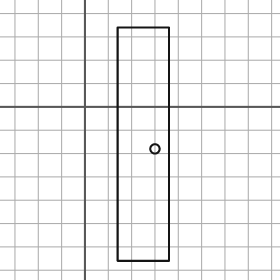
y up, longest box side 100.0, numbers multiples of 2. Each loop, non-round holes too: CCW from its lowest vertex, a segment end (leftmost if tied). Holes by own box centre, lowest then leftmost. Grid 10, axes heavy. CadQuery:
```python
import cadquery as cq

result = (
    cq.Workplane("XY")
    .moveTo(14.0, -66.0)
    .lineTo(36.0, -66.0)
    .lineTo(36.0, 34.0)
    .lineTo(14.0, 34.0)
    .close()
    .moveTo(30.0, -18.0)
    .circle(2.0)
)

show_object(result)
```